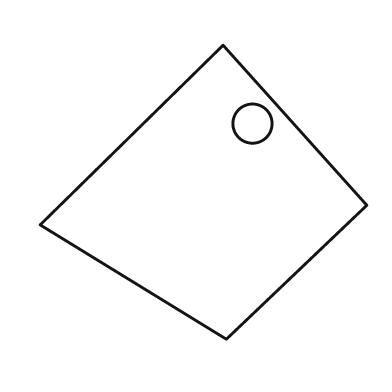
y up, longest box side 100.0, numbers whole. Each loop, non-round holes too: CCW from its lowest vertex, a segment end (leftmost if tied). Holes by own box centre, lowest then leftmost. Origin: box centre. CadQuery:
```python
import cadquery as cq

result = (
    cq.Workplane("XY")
    .moveTo(7.0, -45.0)
    .lineTo(50.0, -4.0)
    .lineTo(6.0, 45.0)
    .lineTo(-50.0, -10.0)
    .close()
    .moveTo(15.0, 21.0)
    .circle(6.0)
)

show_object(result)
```